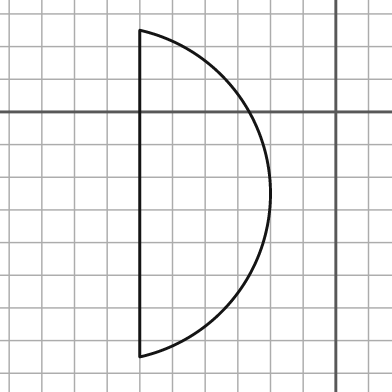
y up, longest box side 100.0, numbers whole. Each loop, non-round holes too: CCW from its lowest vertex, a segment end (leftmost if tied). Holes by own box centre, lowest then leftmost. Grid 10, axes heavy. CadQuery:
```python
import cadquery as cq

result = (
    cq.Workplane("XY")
    .moveTo(-60.0, -75.0)
    .threePointArc((-20.0, -25.0), (-60.0, 25.0))
    .close()
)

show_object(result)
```